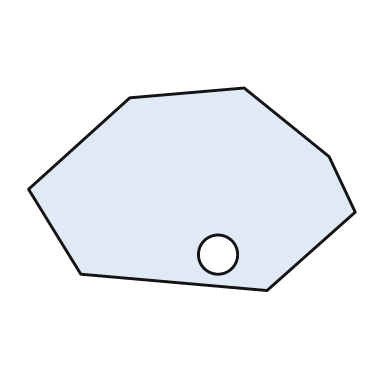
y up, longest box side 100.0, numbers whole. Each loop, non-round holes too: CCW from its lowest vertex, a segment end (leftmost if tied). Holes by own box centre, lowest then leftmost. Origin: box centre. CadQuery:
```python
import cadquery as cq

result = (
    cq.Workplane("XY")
    .moveTo(23.0, -31.0)
    .lineTo(50.0, -7.0)
    .lineTo(42.0, 10.0)
    .lineTo(16.0, 31.0)
    .lineTo(-19.0, 28.0)
    .lineTo(-50.0, 0.0)
    .lineTo(-34.0, -26.0)
    .close()
    .moveTo(8.0, -20.0)
    .circle(6.0)
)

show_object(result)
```